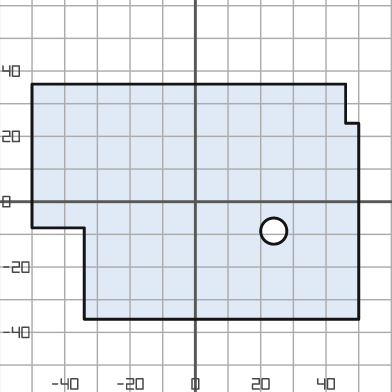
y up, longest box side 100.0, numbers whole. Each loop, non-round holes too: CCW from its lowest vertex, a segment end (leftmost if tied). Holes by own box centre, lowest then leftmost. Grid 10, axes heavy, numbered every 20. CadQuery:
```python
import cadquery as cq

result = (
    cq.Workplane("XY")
    .moveTo(-34.0, -36.0)
    .lineTo(50.0, -36.0)
    .lineTo(50.0, 24.0)
    .lineTo(46.0, 24.0)
    .lineTo(46.0, 36.0)
    .lineTo(-50.0, 36.0)
    .lineTo(-50.0, -8.0)
    .lineTo(-34.0, -8.0)
    .close()
    .moveTo(24.0, -9.0)
    .circle(4.0)
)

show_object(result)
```